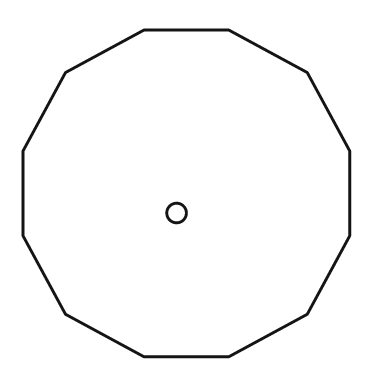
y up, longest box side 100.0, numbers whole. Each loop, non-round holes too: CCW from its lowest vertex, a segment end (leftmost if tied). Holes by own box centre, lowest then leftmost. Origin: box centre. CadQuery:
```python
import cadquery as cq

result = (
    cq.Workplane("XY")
    .moveTo(-13.0, -50.0)
    .lineTo(13.0, -50.0)
    .lineTo(37.0, -37.0)
    .lineTo(50.0, -13.0)
    .lineTo(50.0, 13.0)
    .lineTo(37.0, 37.0)
    .lineTo(13.0, 50.0)
    .lineTo(-13.0, 50.0)
    .lineTo(-37.0, 37.0)
    .lineTo(-50.0, 13.0)
    .lineTo(-50.0, -13.0)
    .lineTo(-37.0, -37.0)
    .close()
    .moveTo(-3.0, -6.0)
    .circle(3.0)
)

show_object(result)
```